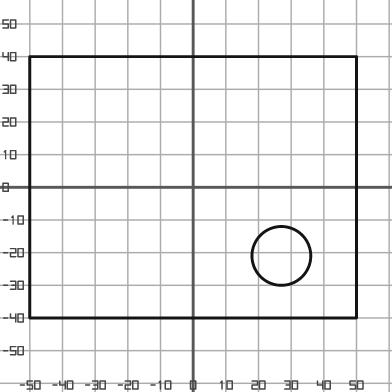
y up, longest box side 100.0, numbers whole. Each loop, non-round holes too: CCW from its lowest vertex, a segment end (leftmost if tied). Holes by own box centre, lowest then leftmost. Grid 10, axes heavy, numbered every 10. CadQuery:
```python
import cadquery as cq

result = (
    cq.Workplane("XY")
    .moveTo(-50.0, -40.0)
    .lineTo(50.0, -40.0)
    .lineTo(50.0, 40.0)
    .lineTo(-50.0, 40.0)
    .close()
    .moveTo(27.0, -21.0)
    .circle(9.0)
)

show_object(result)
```